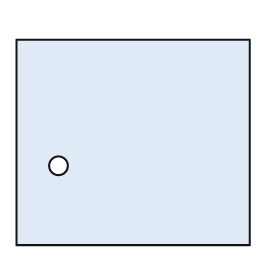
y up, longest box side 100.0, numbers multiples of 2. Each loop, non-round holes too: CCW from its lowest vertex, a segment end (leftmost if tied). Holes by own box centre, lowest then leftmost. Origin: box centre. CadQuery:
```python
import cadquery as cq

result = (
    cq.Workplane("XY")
    .moveTo(-50.0, -44.0)
    .lineTo(50.0, -44.0)
    .lineTo(50.0, 44.0)
    .lineTo(-50.0, 44.0)
    .close()
    .moveTo(-32.0, -10.0)
    .circle(4.0)
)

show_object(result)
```